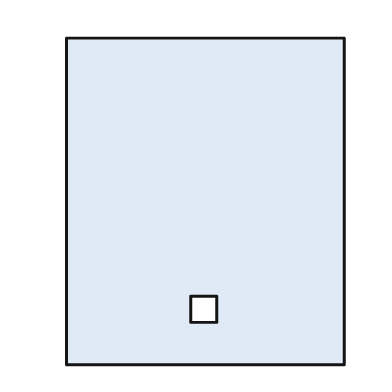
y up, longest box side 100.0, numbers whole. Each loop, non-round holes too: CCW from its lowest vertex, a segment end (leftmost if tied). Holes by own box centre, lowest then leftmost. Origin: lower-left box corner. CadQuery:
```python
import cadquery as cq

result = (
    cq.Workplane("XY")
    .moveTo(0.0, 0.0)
    .lineTo(85.0, 0.0)
    .lineTo(85.0, 100.0)
    .lineTo(0.0, 100.0)
    .close()
    .moveTo(38.0, 13.0)
    .lineTo(46.0, 13.0)
    .lineTo(46.0, 21.0)
    .lineTo(38.0, 21.0)
    .close()
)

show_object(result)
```